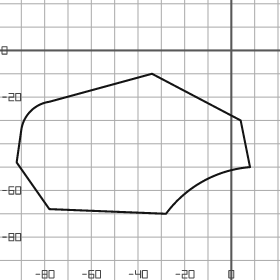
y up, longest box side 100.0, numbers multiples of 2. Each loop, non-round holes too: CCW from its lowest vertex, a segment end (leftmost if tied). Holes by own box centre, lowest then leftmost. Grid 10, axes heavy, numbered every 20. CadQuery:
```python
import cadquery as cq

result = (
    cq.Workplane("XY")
    .moveTo(-28.0, -70.0)
    .threePointArc((-12.0, -56.0), (8.0, -50.0))
    .lineTo(4.0, -30.0)
    .lineTo(-34.0, -10.0)
    .lineTo(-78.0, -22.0)
    .threePointArc((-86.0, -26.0), (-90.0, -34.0))
    .lineTo(-92.0, -48.0)
    .lineTo(-78.0, -68.0)
    .close()
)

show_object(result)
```